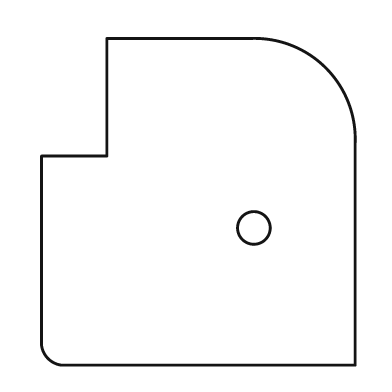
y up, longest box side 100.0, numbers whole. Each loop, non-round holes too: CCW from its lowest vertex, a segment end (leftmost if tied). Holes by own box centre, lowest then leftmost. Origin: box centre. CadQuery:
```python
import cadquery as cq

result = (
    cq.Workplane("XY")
    .moveTo(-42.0, -50.0)
    .lineTo(48.0, -50.0)
    .lineTo(48.0, 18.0)
    .threePointArc((39.0, 41.0), (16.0, 50.0))
    .lineTo(-28.0, 50.0)
    .lineTo(-28.0, 14.0)
    .lineTo(-48.0, 14.0)
    .lineTo(-48.0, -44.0)
    .threePointArc((-46.0, -48.0), (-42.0, -50.0))
    .close()
    .moveTo(17.0, -8.0)
    .circle(5.0)
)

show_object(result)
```